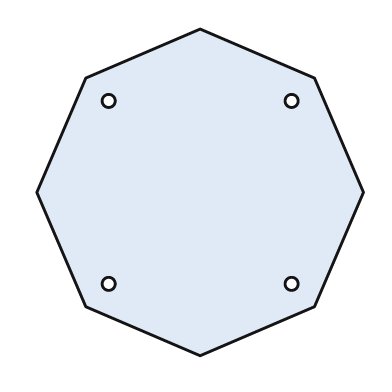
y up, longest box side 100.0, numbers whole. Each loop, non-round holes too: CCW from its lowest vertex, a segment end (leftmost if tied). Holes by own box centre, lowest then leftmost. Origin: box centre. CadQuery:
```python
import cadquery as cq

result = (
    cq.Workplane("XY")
    .moveTo(0.0, -50.0)
    .lineTo(35.0, -35.0)
    .lineTo(50.0, 0.0)
    .lineTo(35.0, 35.0)
    .lineTo(0.0, 50.0)
    .lineTo(-35.0, 35.0)
    .lineTo(-50.0, 0.0)
    .lineTo(-35.0, -35.0)
    .close()
    .moveTo(-28.0, -28.0)
    .circle(2.0)
    .moveTo(28.0, -28.0)
    .circle(2.0)
    .moveTo(-28.0, 28.0)
    .circle(2.0)
    .moveTo(28.0, 28.0)
    .circle(2.0)
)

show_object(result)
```